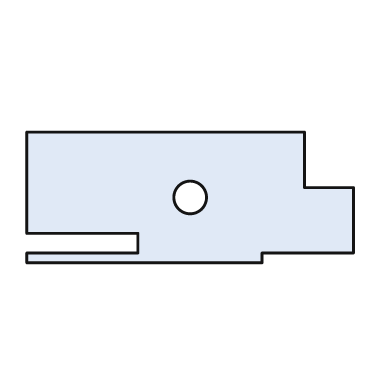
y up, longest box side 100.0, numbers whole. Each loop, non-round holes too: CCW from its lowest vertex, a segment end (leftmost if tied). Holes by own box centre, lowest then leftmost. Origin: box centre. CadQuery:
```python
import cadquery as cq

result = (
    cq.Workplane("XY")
    .moveTo(-50.0, -20.0)
    .lineTo(22.0, -20.0)
    .lineTo(22.0, -17.0)
    .lineTo(50.0, -17.0)
    .lineTo(50.0, 3.0)
    .lineTo(35.0, 3.0)
    .lineTo(35.0, 20.0)
    .lineTo(-50.0, 20.0)
    .lineTo(-50.0, -11.0)
    .lineTo(-16.0, -11.0)
    .lineTo(-16.0, -17.0)
    .lineTo(-50.0, -17.0)
    .close()
    .moveTo(0.0, 0.0)
    .circle(5.0)
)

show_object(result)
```